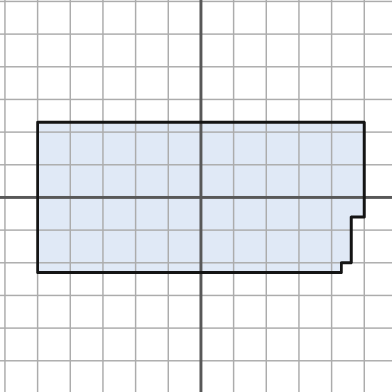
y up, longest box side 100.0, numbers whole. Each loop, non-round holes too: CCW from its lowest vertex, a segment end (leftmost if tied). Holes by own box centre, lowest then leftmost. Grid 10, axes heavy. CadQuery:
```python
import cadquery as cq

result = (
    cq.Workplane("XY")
    .moveTo(-50.0, -23.0)
    .lineTo(43.0, -23.0)
    .lineTo(43.0, -20.0)
    .lineTo(46.0, -20.0)
    .lineTo(46.0, -6.0)
    .lineTo(50.0, -6.0)
    .lineTo(50.0, 23.0)
    .lineTo(-50.0, 23.0)
    .close()
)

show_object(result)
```